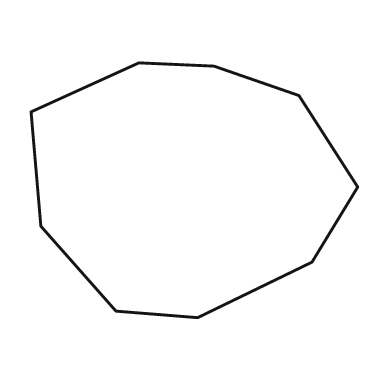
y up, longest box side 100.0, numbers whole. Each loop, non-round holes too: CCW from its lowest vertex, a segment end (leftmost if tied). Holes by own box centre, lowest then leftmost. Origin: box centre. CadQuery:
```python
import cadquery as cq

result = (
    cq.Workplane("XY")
    .moveTo(1.0, -39.0)
    .lineTo(36.0, -22.0)
    .lineTo(50.0, 1.0)
    .lineTo(32.0, 29.0)
    .lineTo(6.0, 38.0)
    .lineTo(-17.0, 39.0)
    .lineTo(-50.0, 24.0)
    .lineTo(-47.0, -11.0)
    .lineTo(-24.0, -37.0)
    .close()
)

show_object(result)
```